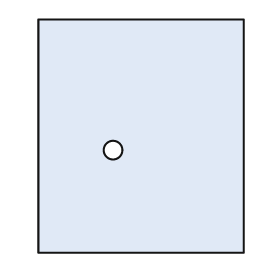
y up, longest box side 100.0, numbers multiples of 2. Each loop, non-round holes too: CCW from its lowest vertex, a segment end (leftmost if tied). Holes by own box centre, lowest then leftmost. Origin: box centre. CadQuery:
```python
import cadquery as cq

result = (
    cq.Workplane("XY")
    .moveTo(-44.0, -50.0)
    .lineTo(44.0, -50.0)
    .lineTo(44.0, 50.0)
    .lineTo(-44.0, 50.0)
    .close()
    .moveTo(-12.0, -6.0)
    .circle(4.0)
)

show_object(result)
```